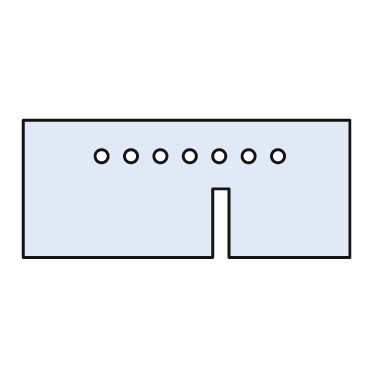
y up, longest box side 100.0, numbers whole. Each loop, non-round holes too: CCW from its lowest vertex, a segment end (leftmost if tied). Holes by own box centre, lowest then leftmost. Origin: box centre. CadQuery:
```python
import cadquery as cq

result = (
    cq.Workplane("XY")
    .moveTo(-50.0, -21.0)
    .lineTo(8.0, -21.0)
    .lineTo(8.0, 0.0)
    .lineTo(13.0, 0.0)
    .lineTo(13.0, -21.0)
    .lineTo(50.0, -21.0)
    .lineTo(50.0, 21.0)
    .lineTo(-50.0, 21.0)
    .close()
    .moveTo(-26.0, 10.0)
    .circle(2.0)
    .moveTo(-17.0, 10.0)
    .circle(2.0)
    .moveTo(-8.0, 10.0)
    .circle(2.0)
    .moveTo(1.0, 10.0)
    .circle(2.0)
    .moveTo(10.0, 10.0)
    .circle(2.0)
    .moveTo(19.0, 10.0)
    .circle(2.0)
    .moveTo(28.0, 10.0)
    .circle(2.0)
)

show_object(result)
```